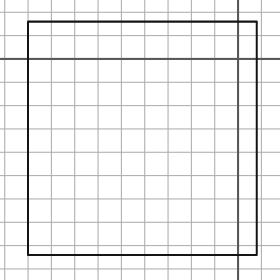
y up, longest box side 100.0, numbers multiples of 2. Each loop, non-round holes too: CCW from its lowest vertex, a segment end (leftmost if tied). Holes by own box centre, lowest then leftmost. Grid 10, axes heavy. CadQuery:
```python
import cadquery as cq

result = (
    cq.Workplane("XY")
    .moveTo(-90.0, -84.0)
    .lineTo(8.0, -84.0)
    .lineTo(8.0, 16.0)
    .lineTo(-90.0, 16.0)
    .close()
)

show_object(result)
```